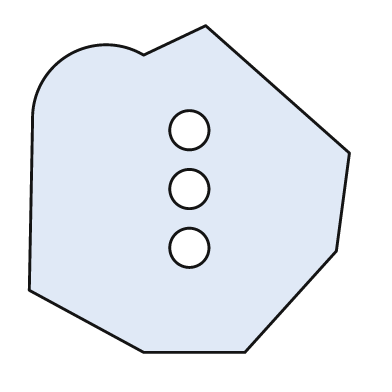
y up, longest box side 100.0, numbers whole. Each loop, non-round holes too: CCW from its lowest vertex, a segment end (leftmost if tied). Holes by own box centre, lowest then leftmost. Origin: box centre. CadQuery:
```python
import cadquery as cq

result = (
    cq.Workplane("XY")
    .moveTo(-14.0, -50.0)
    .lineTo(17.0, -50.0)
    .lineTo(45.0, -19.0)
    .lineTo(49.0, 11.0)
    .lineTo(5.0, 50.0)
    .lineTo(-14.0, 41.0)
    .threePointArc((-37.0, 41.0), (-48.0, 21.0))
    .lineTo(-49.0, -31.0)
    .close()
    .moveTo(0.0, -18.0)
    .circle(6.0)
    .moveTo(0.0, 0.0)
    .circle(6.0)
    .moveTo(0.0, 18.0)
    .circle(6.0)
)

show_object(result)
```